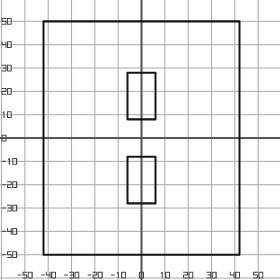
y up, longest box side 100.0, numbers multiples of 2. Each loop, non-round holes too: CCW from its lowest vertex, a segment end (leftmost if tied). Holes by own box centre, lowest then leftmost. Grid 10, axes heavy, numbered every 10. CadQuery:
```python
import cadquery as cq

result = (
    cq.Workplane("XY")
    .moveTo(-42.0, -50.0)
    .lineTo(42.0, -50.0)
    .lineTo(42.0, 50.0)
    .lineTo(-42.0, 50.0)
    .close()
    .moveTo(-6.0, -28.0)
    .lineTo(6.0, -28.0)
    .lineTo(6.0, -8.0)
    .lineTo(-6.0, -8.0)
    .close()
    .moveTo(-6.0, 8.0)
    .lineTo(6.0, 8.0)
    .lineTo(6.0, 28.0)
    .lineTo(-6.0, 28.0)
    .close()
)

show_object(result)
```